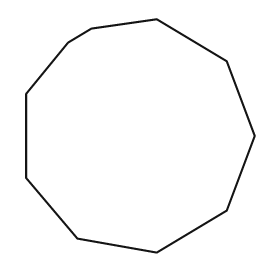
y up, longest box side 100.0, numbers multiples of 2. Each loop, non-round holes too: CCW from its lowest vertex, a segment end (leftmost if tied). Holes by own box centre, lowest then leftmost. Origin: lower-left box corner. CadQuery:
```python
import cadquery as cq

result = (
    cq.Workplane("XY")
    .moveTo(56.0, 0.0)
    .lineTo(86.0, 18.0)
    .lineTo(98.0, 50.0)
    .lineTo(86.0, 82.0)
    .lineTo(56.0, 100.0)
    .lineTo(28.0, 96.0)
    .lineTo(18.0, 90.0)
    .lineTo(0.0, 68.0)
    .lineTo(0.0, 32.0)
    .lineTo(22.0, 6.0)
    .close()
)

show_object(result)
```